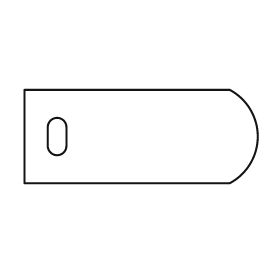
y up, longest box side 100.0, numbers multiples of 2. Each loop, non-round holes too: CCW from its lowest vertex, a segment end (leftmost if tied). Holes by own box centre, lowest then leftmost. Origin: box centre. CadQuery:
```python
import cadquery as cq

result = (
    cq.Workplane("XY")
    .moveTo(-50.0, -20.0)
    .lineTo(38.0, -20.0)
    .threePointArc((50.0, 0.0), (38.0, 20.0))
    .lineTo(-50.0, 20.0)
    .close()
    .moveTo(-40.0, -4.0)
    .threePointArc((-36.0, -8.0), (-32.0, -4.0))
    .lineTo(-32.0, 4.0)
    .threePointArc((-36.0, 8.0), (-40.0, 4.0))
    .close()
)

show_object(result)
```